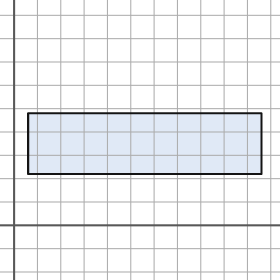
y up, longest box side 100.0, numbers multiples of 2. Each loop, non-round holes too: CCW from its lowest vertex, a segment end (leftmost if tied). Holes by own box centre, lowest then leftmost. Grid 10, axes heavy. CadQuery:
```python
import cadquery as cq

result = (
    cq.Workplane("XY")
    .moveTo(6.0, 22.0)
    .lineTo(106.0, 22.0)
    .lineTo(106.0, 48.0)
    .lineTo(6.0, 48.0)
    .close()
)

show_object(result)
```